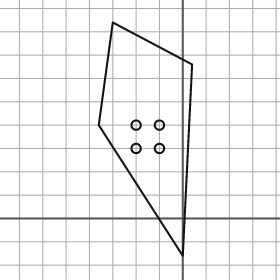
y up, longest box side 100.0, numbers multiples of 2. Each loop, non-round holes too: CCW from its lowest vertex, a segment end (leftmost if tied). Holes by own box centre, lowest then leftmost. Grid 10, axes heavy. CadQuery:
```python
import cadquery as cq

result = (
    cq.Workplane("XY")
    .moveTo(0.0, -16.0)
    .lineTo(4.0, 66.0)
    .lineTo(-30.0, 84.0)
    .lineTo(-36.0, 40.0)
    .close()
    .moveTo(-20.0, 30.0)
    .circle(2.0)
    .moveTo(-10.0, 30.0)
    .circle(2.0)
    .moveTo(-20.0, 40.0)
    .circle(2.0)
    .moveTo(-10.0, 40.0)
    .circle(2.0)
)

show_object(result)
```